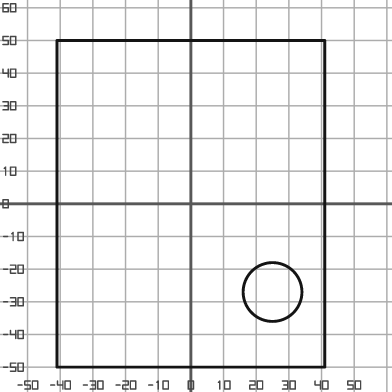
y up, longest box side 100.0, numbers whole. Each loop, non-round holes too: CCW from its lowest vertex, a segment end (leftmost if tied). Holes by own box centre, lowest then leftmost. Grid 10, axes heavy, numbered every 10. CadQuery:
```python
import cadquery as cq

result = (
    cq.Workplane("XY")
    .moveTo(-41.0, -50.0)
    .lineTo(41.0, -50.0)
    .lineTo(41.0, 50.0)
    .lineTo(-41.0, 50.0)
    .close()
    .moveTo(25.0, -27.0)
    .circle(9.0)
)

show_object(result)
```